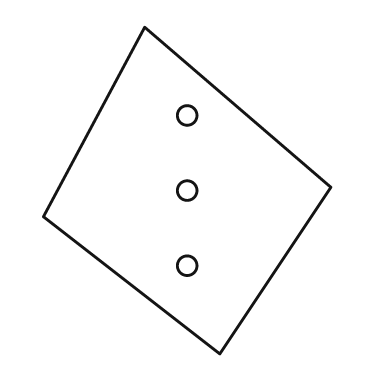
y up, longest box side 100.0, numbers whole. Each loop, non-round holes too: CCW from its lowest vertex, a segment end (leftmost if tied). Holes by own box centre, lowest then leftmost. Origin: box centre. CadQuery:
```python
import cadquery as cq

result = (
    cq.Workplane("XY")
    .moveTo(10.0, -50.0)
    .lineTo(44.0, 1.0)
    .lineTo(-13.0, 50.0)
    .lineTo(-44.0, -8.0)
    .close()
    .moveTo(0.0, -23.0)
    .circle(3.0)
    .moveTo(0.0, 0.0)
    .circle(3.0)
    .moveTo(0.0, 23.0)
    .circle(3.0)
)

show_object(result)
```